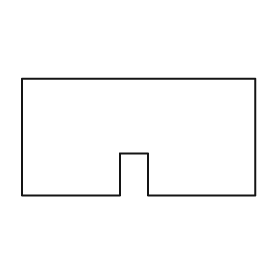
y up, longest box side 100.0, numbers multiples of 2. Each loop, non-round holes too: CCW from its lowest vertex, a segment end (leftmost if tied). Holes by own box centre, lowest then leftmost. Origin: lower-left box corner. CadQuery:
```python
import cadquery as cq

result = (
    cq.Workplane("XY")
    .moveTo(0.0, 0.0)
    .lineTo(42.0, 0.0)
    .lineTo(42.0, 18.0)
    .lineTo(54.0, 18.0)
    .lineTo(54.0, 0.0)
    .lineTo(100.0, 0.0)
    .lineTo(100.0, 50.0)
    .lineTo(0.0, 50.0)
    .close()
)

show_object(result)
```